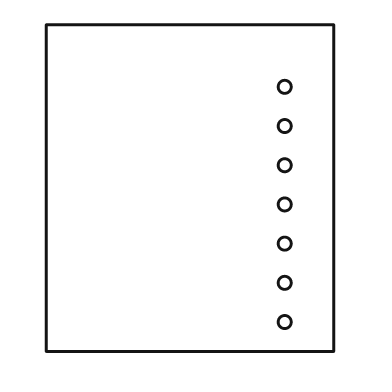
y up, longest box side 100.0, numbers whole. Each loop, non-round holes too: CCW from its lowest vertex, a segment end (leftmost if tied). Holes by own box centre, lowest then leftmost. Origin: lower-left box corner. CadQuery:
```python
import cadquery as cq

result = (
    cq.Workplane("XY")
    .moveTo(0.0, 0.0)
    .lineTo(88.0, 0.0)
    .lineTo(88.0, 100.0)
    .lineTo(0.0, 100.0)
    .close()
    .moveTo(73.0, 9.0)
    .circle(2.0)
    .moveTo(73.0, 21.0)
    .circle(2.0)
    .moveTo(73.0, 33.0)
    .circle(2.0)
    .moveTo(73.0, 45.0)
    .circle(2.0)
    .moveTo(73.0, 57.0)
    .circle(2.0)
    .moveTo(73.0, 69.0)
    .circle(2.0)
    .moveTo(73.0, 81.0)
    .circle(2.0)
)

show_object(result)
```